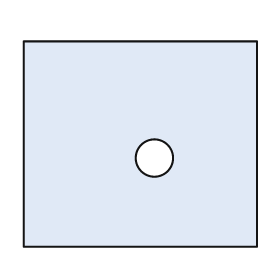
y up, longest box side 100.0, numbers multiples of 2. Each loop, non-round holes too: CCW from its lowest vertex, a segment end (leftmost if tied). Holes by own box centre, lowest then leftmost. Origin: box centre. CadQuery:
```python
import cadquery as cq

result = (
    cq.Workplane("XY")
    .moveTo(-50.0, -44.0)
    .lineTo(50.0, -44.0)
    .lineTo(50.0, 44.0)
    .lineTo(-50.0, 44.0)
    .close()
    .moveTo(6.0, -6.0)
    .circle(8.0)
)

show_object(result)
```